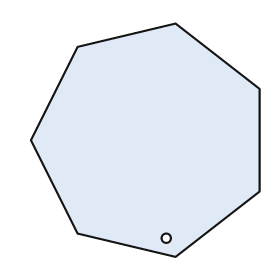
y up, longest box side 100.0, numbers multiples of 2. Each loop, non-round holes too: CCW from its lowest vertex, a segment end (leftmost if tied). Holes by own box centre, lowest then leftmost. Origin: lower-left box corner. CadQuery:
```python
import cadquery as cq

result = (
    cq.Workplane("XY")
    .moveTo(62.0, 0.0)
    .lineTo(98.0, 28.0)
    .lineTo(98.0, 72.0)
    .lineTo(62.0, 100.0)
    .lineTo(20.0, 90.0)
    .lineTo(0.0, 50.0)
    .lineTo(20.0, 10.0)
    .close()
    .moveTo(58.0, 8.0)
    .circle(2.0)
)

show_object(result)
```